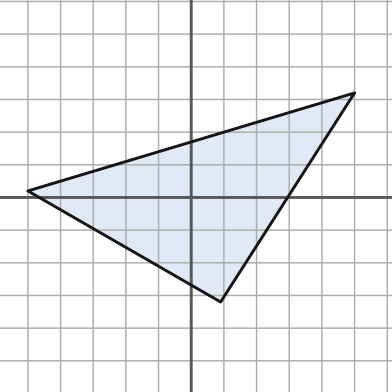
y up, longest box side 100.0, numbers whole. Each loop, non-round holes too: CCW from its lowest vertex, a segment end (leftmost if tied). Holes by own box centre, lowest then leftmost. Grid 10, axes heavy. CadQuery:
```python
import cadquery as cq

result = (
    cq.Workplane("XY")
    .moveTo(9.0, -32.0)
    .lineTo(50.0, 32.0)
    .lineTo(-50.0, 2.0)
    .close()
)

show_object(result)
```